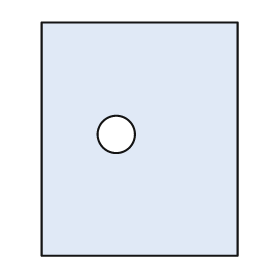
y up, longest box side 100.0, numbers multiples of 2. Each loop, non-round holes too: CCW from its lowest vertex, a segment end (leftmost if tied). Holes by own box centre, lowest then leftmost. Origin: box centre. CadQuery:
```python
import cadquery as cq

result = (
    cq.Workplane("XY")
    .moveTo(-42.0, -50.0)
    .lineTo(42.0, -50.0)
    .lineTo(42.0, 50.0)
    .lineTo(-42.0, 50.0)
    .close()
    .moveTo(-10.0, 2.0)
    .circle(8.0)
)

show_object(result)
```